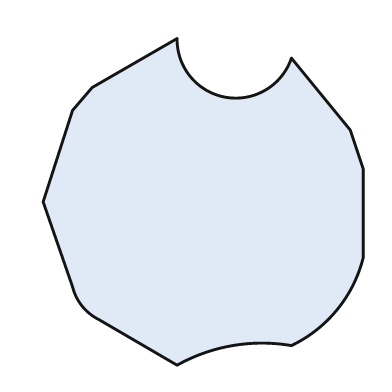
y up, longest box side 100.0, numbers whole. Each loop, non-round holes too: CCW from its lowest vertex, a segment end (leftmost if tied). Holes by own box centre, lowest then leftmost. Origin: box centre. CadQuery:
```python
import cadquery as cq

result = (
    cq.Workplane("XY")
    .moveTo(-8.0, -50.0)
    .threePointArc((9.0, -44.0), (27.0, -44.0))
    .threePointArc((41.0, -33.0), (49.0, -17.0))
    .lineTo(49.0, 10.0)
    .lineTo(45.0, 22.0)
    .lineTo(27.0, 44.0)
    .threePointArc((7.0, 32.0), (-8.0, 50.0))
    .lineTo(-34.0, 35.0)
    .lineTo(-40.0, 28.0)
    .lineTo(-49.0, 0.0)
    .lineTo(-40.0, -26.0)
    .threePointArc((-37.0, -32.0), (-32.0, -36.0))
    .close()
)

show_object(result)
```